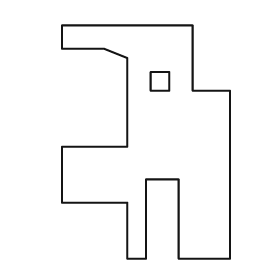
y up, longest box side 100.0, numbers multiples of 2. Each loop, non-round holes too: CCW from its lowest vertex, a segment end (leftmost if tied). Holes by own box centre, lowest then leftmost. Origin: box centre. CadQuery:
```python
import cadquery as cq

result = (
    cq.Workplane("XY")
    .moveTo(-8.0, -50.0)
    .lineTo(0.0, -50.0)
    .lineTo(0.0, -16.0)
    .lineTo(14.0, -16.0)
    .lineTo(14.0, -50.0)
    .lineTo(36.0, -50.0)
    .lineTo(36.0, 22.0)
    .lineTo(20.0, 22.0)
    .lineTo(20.0, 50.0)
    .lineTo(-36.0, 50.0)
    .lineTo(-36.0, 40.0)
    .lineTo(-18.0, 40.0)
    .lineTo(-8.0, 36.0)
    .lineTo(-8.0, -2.0)
    .lineTo(-36.0, -2.0)
    .lineTo(-36.0, -26.0)
    .lineTo(-8.0, -26.0)
    .close()
    .moveTo(2.0, 22.0)
    .lineTo(10.0, 22.0)
    .lineTo(10.0, 30.0)
    .lineTo(2.0, 30.0)
    .close()
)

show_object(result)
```